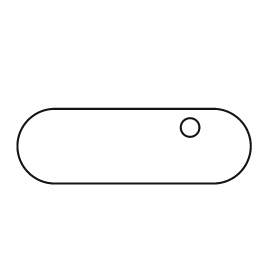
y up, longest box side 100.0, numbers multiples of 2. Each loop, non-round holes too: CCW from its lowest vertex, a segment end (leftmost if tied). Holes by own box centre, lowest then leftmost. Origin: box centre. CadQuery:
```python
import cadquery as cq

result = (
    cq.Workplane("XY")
    .moveTo(-34.0, -16.0)
    .lineTo(34.0, -16.0)
    .threePointArc((50.0, 0.0), (34.0, 16.0))
    .lineTo(-34.0, 16.0)
    .threePointArc((-50.0, 0.0), (-34.0, -16.0))
    .close()
    .moveTo(24.0, 8.0)
    .circle(4.0)
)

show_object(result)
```